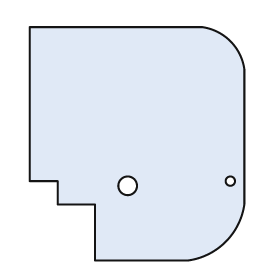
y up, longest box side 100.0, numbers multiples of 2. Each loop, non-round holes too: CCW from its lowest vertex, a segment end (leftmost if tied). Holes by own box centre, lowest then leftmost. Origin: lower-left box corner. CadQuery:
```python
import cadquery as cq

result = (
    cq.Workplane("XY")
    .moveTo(28.0, 0.0)
    .lineTo(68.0, 0.0)
    .threePointArc((84.0, 8.0), (92.0, 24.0))
    .lineTo(92.0, 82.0)
    .threePointArc((86.0, 94.0), (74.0, 100.0))
    .lineTo(0.0, 100.0)
    .lineTo(0.0, 34.0)
    .lineTo(12.0, 34.0)
    .lineTo(12.0, 24.0)
    .lineTo(28.0, 24.0)
    .close()
    .moveTo(42.0, 32.0)
    .circle(4.0)
    .moveTo(86.0, 34.0)
    .circle(2.0)
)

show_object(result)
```